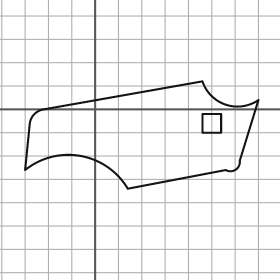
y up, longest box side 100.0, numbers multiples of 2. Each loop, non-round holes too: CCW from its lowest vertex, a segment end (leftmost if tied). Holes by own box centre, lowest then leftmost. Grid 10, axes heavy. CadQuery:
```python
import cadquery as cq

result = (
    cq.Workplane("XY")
    .moveTo(14.0, -34.0)
    .lineTo(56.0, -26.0)
    .threePointArc((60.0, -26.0), (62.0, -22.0))
    .lineTo(70.0, 4.0)
    .threePointArc((56.0, 2.0), (46.0, 12.0))
    .lineTo(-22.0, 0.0)
    .threePointArc((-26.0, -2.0), (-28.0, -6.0))
    .lineTo(-30.0, -26.0)
    .threePointArc((-6.0, -20.0), (14.0, -34.0))
    .close()
    .moveTo(46.0, -10.0)
    .lineTo(54.0, -10.0)
    .lineTo(54.0, -2.0)
    .lineTo(46.0, -2.0)
    .close()
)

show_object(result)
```